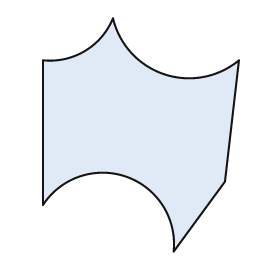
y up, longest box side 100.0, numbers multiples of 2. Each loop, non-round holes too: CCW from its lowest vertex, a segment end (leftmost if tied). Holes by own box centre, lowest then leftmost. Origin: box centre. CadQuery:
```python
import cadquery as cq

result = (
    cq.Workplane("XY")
    .moveTo(14.0, -50.0)
    .lineTo(36.0, -20.0)
    .lineTo(42.0, 32.0)
    .threePointArc((10.0, 26.0), (-12.0, 50.0))
    .threePointArc((-24.0, 36.0), (-42.0, 32.0))
    .lineTo(-42.0, -30.0)
    .threePointArc((-6.0, -18.0), (14.0, -50.0))
    .close()
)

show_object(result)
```